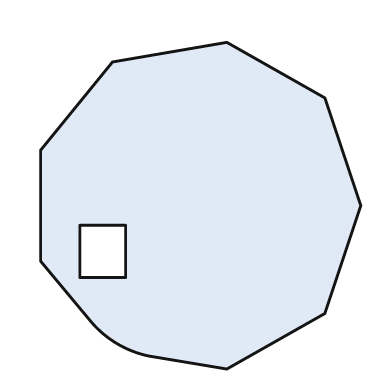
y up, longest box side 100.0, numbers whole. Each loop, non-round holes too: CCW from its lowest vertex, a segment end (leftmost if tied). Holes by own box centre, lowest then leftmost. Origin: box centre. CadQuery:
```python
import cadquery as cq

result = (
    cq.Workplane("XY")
    .moveTo(8.0, -50.0)
    .lineTo(38.0, -33.0)
    .lineTo(49.0, 0.0)
    .lineTo(38.0, 33.0)
    .lineTo(8.0, 50.0)
    .lineTo(-27.0, 44.0)
    .lineTo(-49.0, 17.0)
    .lineTo(-49.0, -17.0)
    .lineTo(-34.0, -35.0)
    .threePointArc((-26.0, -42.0), (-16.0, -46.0))
    .close()
    .moveTo(-37.0, -22.0)
    .lineTo(-23.0, -22.0)
    .lineTo(-23.0, -6.0)
    .lineTo(-37.0, -6.0)
    .close()
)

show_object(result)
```